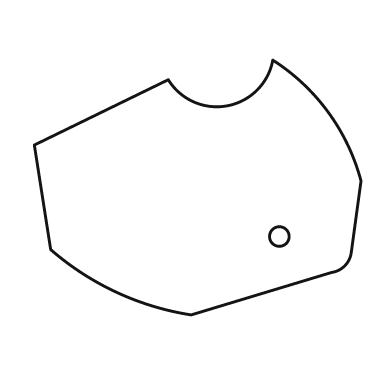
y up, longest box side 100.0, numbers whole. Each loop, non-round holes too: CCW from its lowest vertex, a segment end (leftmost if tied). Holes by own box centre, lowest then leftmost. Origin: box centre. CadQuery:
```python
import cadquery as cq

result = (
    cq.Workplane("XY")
    .moveTo(-2.0, -39.0)
    .lineTo(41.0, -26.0)
    .threePointArc((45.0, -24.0), (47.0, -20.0))
    .lineTo(50.0, 2.0)
    .threePointArc((40.0, 23.0), (23.0, 39.0))
    .threePointArc((9.0, 25.0), (-9.0, 33.0))
    .lineTo(-50.0, 13.0)
    .lineTo(-45.0, -19.0)
    .threePointArc((-25.0, -32.0), (-2.0, -39.0))
    .close()
    .moveTo(25.0, -15.0)
    .circle(3.0)
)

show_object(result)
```